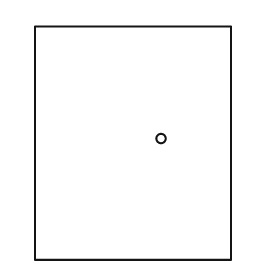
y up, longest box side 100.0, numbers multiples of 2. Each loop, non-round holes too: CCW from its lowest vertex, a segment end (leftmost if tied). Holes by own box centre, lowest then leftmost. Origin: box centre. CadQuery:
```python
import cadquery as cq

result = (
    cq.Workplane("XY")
    .moveTo(-42.0, -50.0)
    .lineTo(42.0, -50.0)
    .lineTo(42.0, 50.0)
    .lineTo(-42.0, 50.0)
    .close()
    .moveTo(12.0, 2.0)
    .circle(2.0)
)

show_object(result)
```